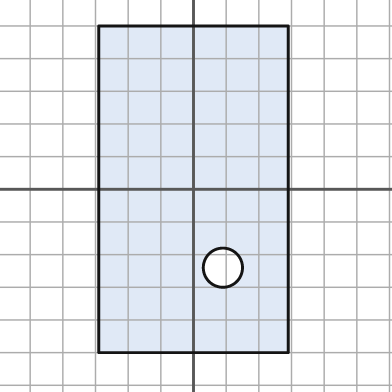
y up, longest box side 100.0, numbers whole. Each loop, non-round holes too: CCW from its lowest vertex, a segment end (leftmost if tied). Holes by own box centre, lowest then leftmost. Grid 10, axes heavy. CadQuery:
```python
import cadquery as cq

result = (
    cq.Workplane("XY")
    .moveTo(-29.0, -50.0)
    .lineTo(29.0, -50.0)
    .lineTo(29.0, 50.0)
    .lineTo(-29.0, 50.0)
    .close()
    .moveTo(9.0, -24.0)
    .circle(6.0)
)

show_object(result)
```